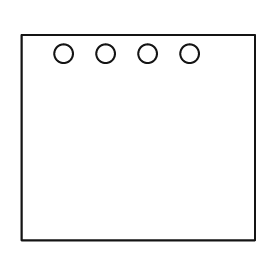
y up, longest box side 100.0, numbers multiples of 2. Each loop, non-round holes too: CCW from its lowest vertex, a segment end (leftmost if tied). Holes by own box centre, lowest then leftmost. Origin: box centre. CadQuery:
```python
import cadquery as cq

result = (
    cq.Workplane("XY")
    .moveTo(-50.0, -44.0)
    .lineTo(50.0, -44.0)
    .lineTo(50.0, 44.0)
    .lineTo(-50.0, 44.0)
    .close()
    .moveTo(-32.0, 36.0)
    .circle(4.0)
    .moveTo(-14.0, 36.0)
    .circle(4.0)
    .moveTo(4.0, 36.0)
    .circle(4.0)
    .moveTo(22.0, 36.0)
    .circle(4.0)
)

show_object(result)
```